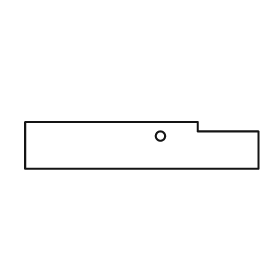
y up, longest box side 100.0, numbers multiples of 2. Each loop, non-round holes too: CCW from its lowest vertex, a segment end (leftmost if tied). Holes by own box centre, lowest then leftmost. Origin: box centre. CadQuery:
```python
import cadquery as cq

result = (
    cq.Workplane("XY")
    .moveTo(-50.0, -10.0)
    .lineTo(50.0, -10.0)
    .lineTo(50.0, 6.0)
    .lineTo(24.0, 6.0)
    .lineTo(24.0, 10.0)
    .lineTo(-50.0, 10.0)
    .close()
    .moveTo(8.0, 4.0)
    .circle(2.0)
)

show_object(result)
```